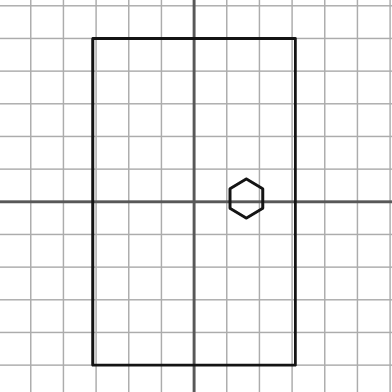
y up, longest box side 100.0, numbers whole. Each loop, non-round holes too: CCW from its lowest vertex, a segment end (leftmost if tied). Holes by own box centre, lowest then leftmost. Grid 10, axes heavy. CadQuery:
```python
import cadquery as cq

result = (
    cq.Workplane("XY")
    .moveTo(-31.0, -50.0)
    .lineTo(31.0, -50.0)
    .lineTo(31.0, 50.0)
    .lineTo(-31.0, 50.0)
    .close()
    .moveTo(16.0, -5.0)
    .lineTo(21.0, -2.0)
    .lineTo(21.0, 4.0)
    .lineTo(16.0, 7.0)
    .lineTo(11.0, 4.0)
    .lineTo(11.0, -2.0)
    .close()
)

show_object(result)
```